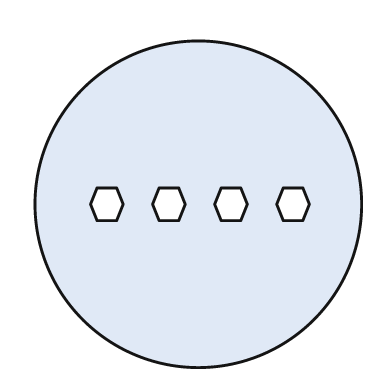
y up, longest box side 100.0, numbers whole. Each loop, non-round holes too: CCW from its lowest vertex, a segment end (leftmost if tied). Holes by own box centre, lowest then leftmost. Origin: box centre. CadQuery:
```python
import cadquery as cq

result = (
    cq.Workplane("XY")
    .moveTo(0.0, 0.0)
    .circle(50.0)
    .moveTo(-31.0, -5.0)
    .lineTo(-25.0, -5.0)
    .lineTo(-23.0, 0.0)
    .lineTo(-25.0, 5.0)
    .lineTo(-31.0, 5.0)
    .lineTo(-33.0, 0.0)
    .close()
    .moveTo(-12.0, -5.0)
    .lineTo(-6.0, -5.0)
    .lineTo(-4.0, 0.0)
    .lineTo(-6.0, 5.0)
    .lineTo(-12.0, 5.0)
    .lineTo(-14.0, 0.0)
    .close()
    .moveTo(7.0, -5.0)
    .lineTo(13.0, -5.0)
    .lineTo(15.0, 0.0)
    .lineTo(13.0, 5.0)
    .lineTo(7.0, 5.0)
    .lineTo(5.0, 0.0)
    .close()
    .moveTo(26.0, -5.0)
    .lineTo(32.0, -5.0)
    .lineTo(34.0, 0.0)
    .lineTo(32.0, 5.0)
    .lineTo(26.0, 5.0)
    .lineTo(24.0, 0.0)
    .close()
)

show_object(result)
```